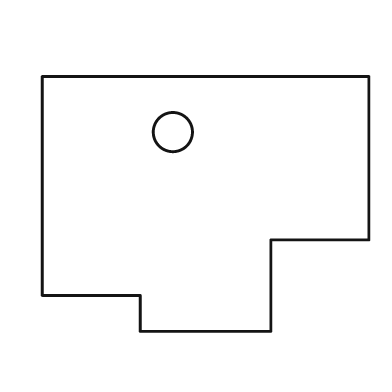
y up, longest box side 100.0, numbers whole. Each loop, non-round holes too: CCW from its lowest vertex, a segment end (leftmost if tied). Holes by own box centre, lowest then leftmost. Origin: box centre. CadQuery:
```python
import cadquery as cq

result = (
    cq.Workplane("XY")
    .moveTo(-20.0, -39.0)
    .lineTo(20.0, -39.0)
    .lineTo(20.0, -11.0)
    .lineTo(50.0, -11.0)
    .lineTo(50.0, 39.0)
    .lineTo(-50.0, 39.0)
    .lineTo(-50.0, -28.0)
    .lineTo(-20.0, -28.0)
    .close()
    .moveTo(-10.0, 22.0)
    .circle(6.0)
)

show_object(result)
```